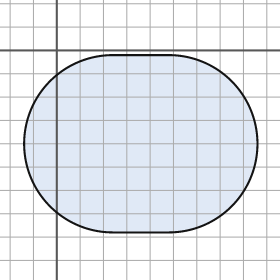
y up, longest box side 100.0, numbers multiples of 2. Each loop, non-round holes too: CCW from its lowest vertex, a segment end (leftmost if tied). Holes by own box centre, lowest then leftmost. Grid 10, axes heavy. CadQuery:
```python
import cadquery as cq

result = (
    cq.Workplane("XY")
    .moveTo(24.0, -78.0)
    .lineTo(48.0, -78.0)
    .threePointArc((86.0, -40.0), (48.0, -2.0))
    .lineTo(24.0, -2.0)
    .threePointArc((-14.0, -40.0), (24.0, -78.0))
    .close()
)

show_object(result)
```